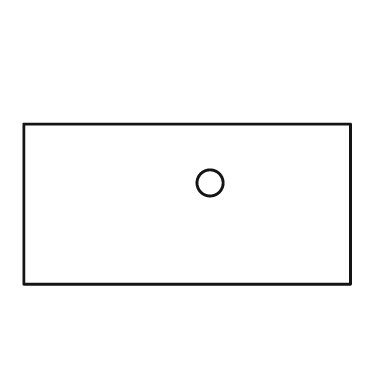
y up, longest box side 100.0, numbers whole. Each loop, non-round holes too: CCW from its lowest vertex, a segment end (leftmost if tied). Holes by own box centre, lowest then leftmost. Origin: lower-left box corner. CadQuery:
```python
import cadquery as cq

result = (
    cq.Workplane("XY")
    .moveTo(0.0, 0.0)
    .lineTo(100.0, 0.0)
    .lineTo(100.0, 49.0)
    .lineTo(0.0, 49.0)
    .close()
    .moveTo(57.0, 31.0)
    .circle(4.0)
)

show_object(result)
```